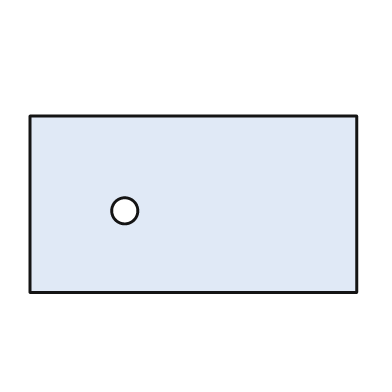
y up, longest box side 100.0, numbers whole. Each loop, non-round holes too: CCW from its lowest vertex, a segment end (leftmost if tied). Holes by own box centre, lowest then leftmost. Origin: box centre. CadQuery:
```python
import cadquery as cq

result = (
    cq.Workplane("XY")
    .moveTo(-50.0, -27.0)
    .lineTo(50.0, -27.0)
    .lineTo(50.0, 27.0)
    .lineTo(-50.0, 27.0)
    .close()
    .moveTo(-21.0, -2.0)
    .circle(4.0)
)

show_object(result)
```